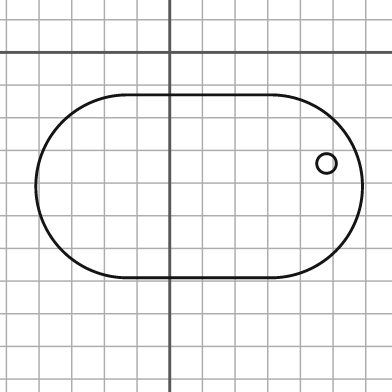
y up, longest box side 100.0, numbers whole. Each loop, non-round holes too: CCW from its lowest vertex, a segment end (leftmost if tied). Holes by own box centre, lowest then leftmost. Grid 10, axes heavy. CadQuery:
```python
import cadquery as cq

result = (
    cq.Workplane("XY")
    .moveTo(-13.0, -69.0)
    .lineTo(31.0, -69.0)
    .threePointArc((59.0, -41.0), (31.0, -13.0))
    .lineTo(-13.0, -13.0)
    .threePointArc((-41.0, -41.0), (-13.0, -69.0))
    .close()
    .moveTo(48.0, -34.0)
    .circle(3.0)
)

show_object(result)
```